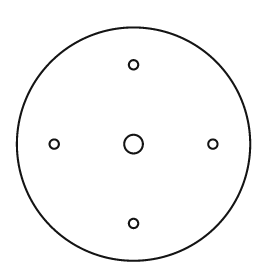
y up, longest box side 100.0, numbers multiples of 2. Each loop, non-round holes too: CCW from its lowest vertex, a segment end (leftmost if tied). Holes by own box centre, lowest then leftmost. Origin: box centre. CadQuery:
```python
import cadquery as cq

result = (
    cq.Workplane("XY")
    .moveTo(0.0, 0.0)
    .circle(50.0)
    .moveTo(0.0, -34.0)
    .circle(2.0)
    .moveTo(-34.0, 0.0)
    .circle(2.0)
    .moveTo(0.0, 0.0)
    .circle(4.0)
    .moveTo(34.0, 0.0)
    .circle(2.0)
    .moveTo(0.0, 34.0)
    .circle(2.0)
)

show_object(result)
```